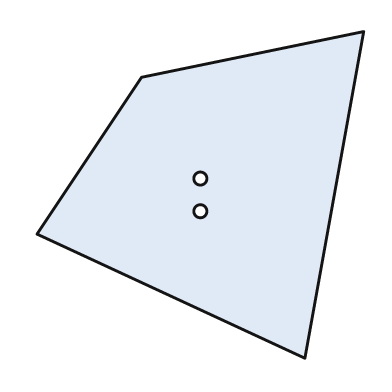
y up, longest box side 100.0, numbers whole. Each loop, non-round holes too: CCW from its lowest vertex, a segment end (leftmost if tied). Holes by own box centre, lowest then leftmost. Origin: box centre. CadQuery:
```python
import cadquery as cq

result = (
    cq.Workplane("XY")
    .moveTo(32.0, -50.0)
    .lineTo(50.0, 50.0)
    .lineTo(-18.0, 36.0)
    .lineTo(-50.0, -12.0)
    .close()
    .moveTo(0.0, -5.0)
    .circle(2.0)
    .moveTo(0.0, 5.0)
    .circle(2.0)
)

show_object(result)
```